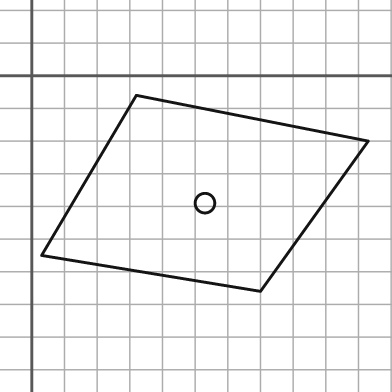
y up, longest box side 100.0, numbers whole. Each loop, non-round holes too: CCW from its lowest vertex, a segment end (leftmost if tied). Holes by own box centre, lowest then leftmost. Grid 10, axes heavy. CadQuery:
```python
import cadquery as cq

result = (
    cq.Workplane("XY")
    .moveTo(70.0, -66.0)
    .lineTo(103.0, -20.0)
    .lineTo(32.0, -6.0)
    .lineTo(3.0, -55.0)
    .close()
    .moveTo(53.0, -39.0)
    .circle(3.0)
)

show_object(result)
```